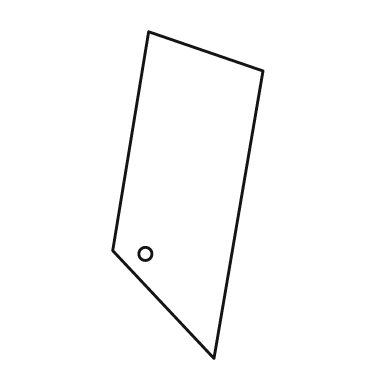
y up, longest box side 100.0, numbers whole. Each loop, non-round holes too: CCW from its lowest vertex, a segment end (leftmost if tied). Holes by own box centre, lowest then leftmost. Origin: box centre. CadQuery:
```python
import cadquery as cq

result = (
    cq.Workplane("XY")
    .moveTo(8.0, -50.0)
    .lineTo(23.0, 38.0)
    .lineTo(-12.0, 50.0)
    .lineTo(-23.0, -17.0)
    .close()
    .moveTo(-13.0, -18.0)
    .circle(2.0)
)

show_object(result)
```